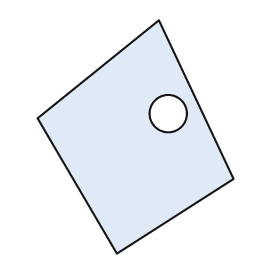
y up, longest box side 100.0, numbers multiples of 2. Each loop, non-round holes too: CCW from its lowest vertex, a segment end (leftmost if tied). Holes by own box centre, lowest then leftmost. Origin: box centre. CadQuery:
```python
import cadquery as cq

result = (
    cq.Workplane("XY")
    .moveTo(-8.0, -50.0)
    .lineTo(42.0, -18.0)
    .lineTo(10.0, 50.0)
    .lineTo(-42.0, 8.0)
    .close()
    .moveTo(14.0, 10.0)
    .circle(8.0)
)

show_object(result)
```